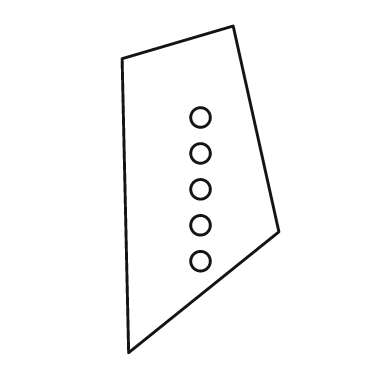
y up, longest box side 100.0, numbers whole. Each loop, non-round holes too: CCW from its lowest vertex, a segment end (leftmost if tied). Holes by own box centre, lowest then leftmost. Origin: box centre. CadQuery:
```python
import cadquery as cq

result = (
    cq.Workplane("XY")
    .moveTo(-22.0, -50.0)
    .lineTo(24.0, -13.0)
    .lineTo(10.0, 50.0)
    .lineTo(-24.0, 40.0)
    .close()
    .moveTo(0.0, -22.0)
    .circle(3.0)
    .moveTo(0.0, -11.0)
    .circle(3.0)
    .moveTo(0.0, 0.0)
    .circle(3.0)
    .moveTo(0.0, 11.0)
    .circle(3.0)
    .moveTo(0.0, 22.0)
    .circle(3.0)
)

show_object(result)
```